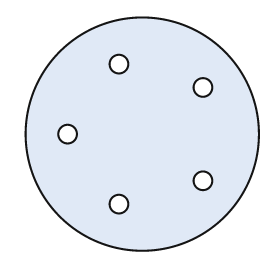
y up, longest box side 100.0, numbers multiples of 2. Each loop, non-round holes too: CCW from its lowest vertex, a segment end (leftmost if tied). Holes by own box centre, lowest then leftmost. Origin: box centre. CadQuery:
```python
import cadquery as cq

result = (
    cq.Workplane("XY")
    .moveTo(0.0, 0.0)
    .circle(50.0)
    .moveTo(-10.0, -30.0)
    .circle(4.0)
    .moveTo(26.0, -20.0)
    .circle(4.0)
    .moveTo(-32.0, 0.0)
    .circle(4.0)
    .moveTo(26.0, 20.0)
    .circle(4.0)
    .moveTo(-10.0, 30.0)
    .circle(4.0)
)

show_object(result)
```